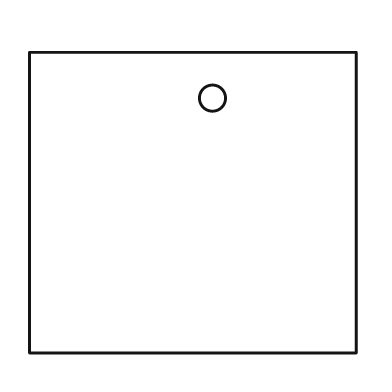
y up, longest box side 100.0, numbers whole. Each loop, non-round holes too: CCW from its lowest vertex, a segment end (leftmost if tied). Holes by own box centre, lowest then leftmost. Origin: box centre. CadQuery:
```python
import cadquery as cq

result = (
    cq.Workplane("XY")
    .moveTo(-50.0, -46.0)
    .lineTo(50.0, -46.0)
    .lineTo(50.0, 46.0)
    .lineTo(-50.0, 46.0)
    .close()
    .moveTo(6.0, 32.0)
    .circle(4.0)
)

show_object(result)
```